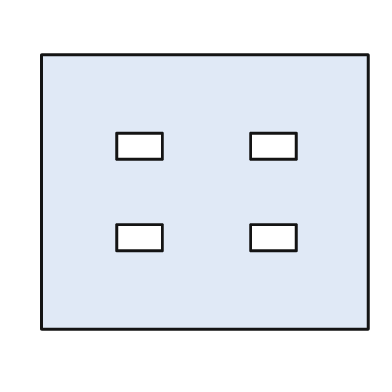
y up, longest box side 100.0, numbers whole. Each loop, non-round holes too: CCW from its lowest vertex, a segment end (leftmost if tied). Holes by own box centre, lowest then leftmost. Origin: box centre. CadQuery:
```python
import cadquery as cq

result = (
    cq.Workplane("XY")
    .moveTo(-50.0, -42.0)
    .lineTo(50.0, -42.0)
    .lineTo(50.0, 42.0)
    .lineTo(-50.0, 42.0)
    .close()
    .moveTo(-27.0, -18.0)
    .lineTo(-13.0, -18.0)
    .lineTo(-13.0, -10.0)
    .lineTo(-27.0, -10.0)
    .close()
    .moveTo(14.0, -18.0)
    .lineTo(28.0, -18.0)
    .lineTo(28.0, -10.0)
    .lineTo(14.0, -10.0)
    .close()
    .moveTo(-27.0, 10.0)
    .lineTo(-13.0, 10.0)
    .lineTo(-13.0, 18.0)
    .lineTo(-27.0, 18.0)
    .close()
    .moveTo(14.0, 10.0)
    .lineTo(28.0, 10.0)
    .lineTo(28.0, 18.0)
    .lineTo(14.0, 18.0)
    .close()
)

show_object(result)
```